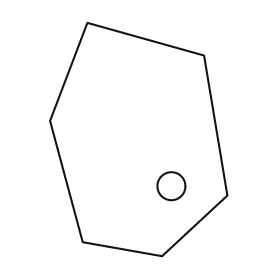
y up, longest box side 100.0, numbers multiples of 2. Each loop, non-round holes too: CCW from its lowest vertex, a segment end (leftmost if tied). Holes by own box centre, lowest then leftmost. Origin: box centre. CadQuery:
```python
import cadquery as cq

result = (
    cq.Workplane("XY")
    .moveTo(10.0, -50.0)
    .lineTo(38.0, -24.0)
    .lineTo(28.0, 36.0)
    .lineTo(-22.0, 50.0)
    .lineTo(-38.0, 8.0)
    .lineTo(-24.0, -44.0)
    .close()
    .moveTo(14.0, -20.0)
    .circle(6.0)
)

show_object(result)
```